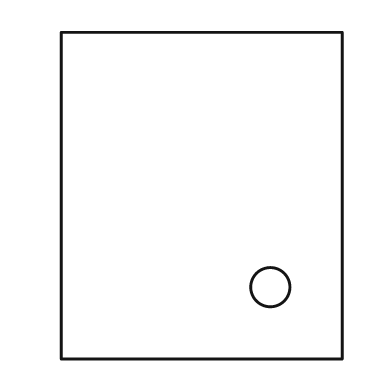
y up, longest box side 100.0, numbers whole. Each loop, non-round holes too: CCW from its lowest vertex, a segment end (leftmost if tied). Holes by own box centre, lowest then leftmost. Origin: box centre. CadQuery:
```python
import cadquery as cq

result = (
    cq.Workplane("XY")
    .moveTo(-43.0, -50.0)
    .lineTo(43.0, -50.0)
    .lineTo(43.0, 50.0)
    .lineTo(-43.0, 50.0)
    .close()
    .moveTo(21.0, -28.0)
    .circle(6.0)
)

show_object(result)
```